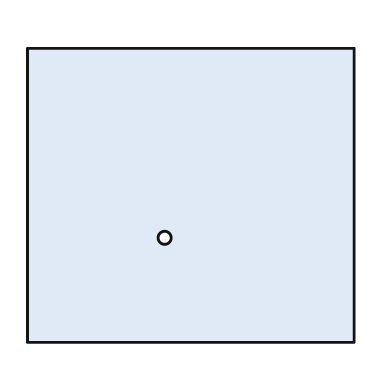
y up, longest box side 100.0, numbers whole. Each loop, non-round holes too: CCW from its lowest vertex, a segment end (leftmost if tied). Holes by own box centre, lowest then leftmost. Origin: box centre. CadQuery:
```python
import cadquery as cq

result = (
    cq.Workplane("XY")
    .moveTo(-50.0, -45.0)
    .lineTo(50.0, -45.0)
    .lineTo(50.0, 45.0)
    .lineTo(-50.0, 45.0)
    .close()
    .moveTo(-8.0, -13.0)
    .circle(2.0)
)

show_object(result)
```